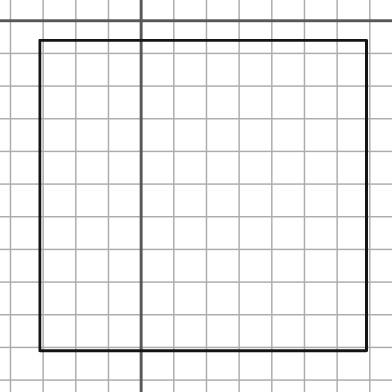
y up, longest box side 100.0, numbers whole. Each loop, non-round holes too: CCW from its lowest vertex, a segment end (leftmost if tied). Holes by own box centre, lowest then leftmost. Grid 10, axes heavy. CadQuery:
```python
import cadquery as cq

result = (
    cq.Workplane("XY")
    .moveTo(-31.0, -101.0)
    .lineTo(69.0, -101.0)
    .lineTo(69.0, -6.0)
    .lineTo(-31.0, -6.0)
    .close()
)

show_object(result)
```